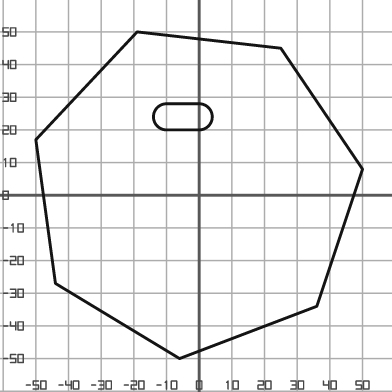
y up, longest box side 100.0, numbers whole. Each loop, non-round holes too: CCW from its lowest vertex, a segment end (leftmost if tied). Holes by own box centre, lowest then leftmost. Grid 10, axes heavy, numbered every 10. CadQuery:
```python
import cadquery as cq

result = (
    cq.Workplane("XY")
    .moveTo(-6.0, -50.0)
    .lineTo(36.0, -34.0)
    .lineTo(50.0, 8.0)
    .lineTo(25.0, 45.0)
    .lineTo(-19.0, 50.0)
    .lineTo(-50.0, 17.0)
    .lineTo(-44.0, -27.0)
    .close()
    .moveTo(-10.0, 20.0)
    .lineTo(0.0, 20.0)
    .threePointArc((4.0, 24.0), (0.0, 28.0))
    .lineTo(-10.0, 28.0)
    .threePointArc((-14.0, 24.0), (-10.0, 20.0))
    .close()
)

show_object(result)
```